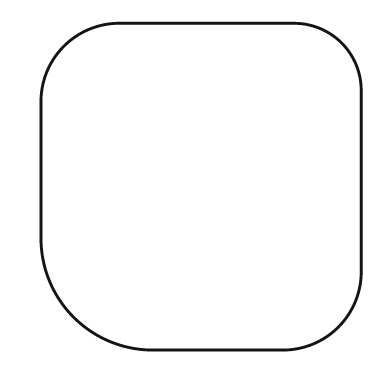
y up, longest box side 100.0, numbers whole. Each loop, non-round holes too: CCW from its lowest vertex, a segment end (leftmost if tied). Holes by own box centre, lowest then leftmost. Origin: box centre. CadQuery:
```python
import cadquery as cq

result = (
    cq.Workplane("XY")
    .moveTo(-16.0, -50.0)
    .lineTo(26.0, -50.0)
    .threePointArc((42.0, -43.0), (49.0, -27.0))
    .lineTo(49.0, 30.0)
    .threePointArc((43.0, 44.0), (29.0, 50.0))
    .lineTo(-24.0, 50.0)
    .threePointArc((-42.0, 43.0), (-49.0, 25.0))
    .lineTo(-49.0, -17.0)
    .threePointArc((-39.0, -40.0), (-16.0, -50.0))
    .close()
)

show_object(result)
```